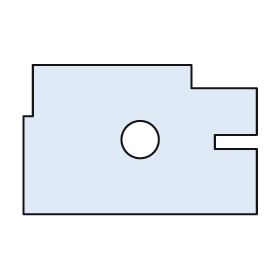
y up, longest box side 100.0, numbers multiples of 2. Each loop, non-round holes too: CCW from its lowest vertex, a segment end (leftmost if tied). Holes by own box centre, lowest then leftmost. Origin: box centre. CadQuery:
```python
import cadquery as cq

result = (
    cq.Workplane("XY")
    .moveTo(-50.0, -32.0)
    .lineTo(50.0, -32.0)
    .lineTo(50.0, -4.0)
    .lineTo(32.0, -4.0)
    .lineTo(32.0, 2.0)
    .lineTo(50.0, 2.0)
    .lineTo(50.0, 22.0)
    .lineTo(22.0, 22.0)
    .lineTo(22.0, 32.0)
    .lineTo(-46.0, 32.0)
    .lineTo(-46.0, 10.0)
    .lineTo(-50.0, 10.0)
    .close()
    .moveTo(0.0, 0.0)
    .circle(8.0)
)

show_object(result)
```